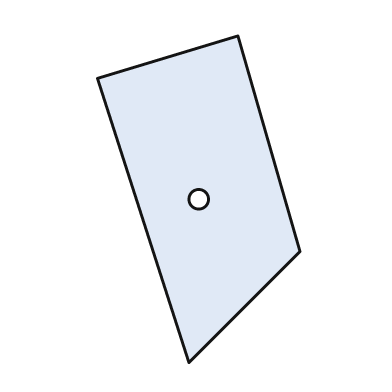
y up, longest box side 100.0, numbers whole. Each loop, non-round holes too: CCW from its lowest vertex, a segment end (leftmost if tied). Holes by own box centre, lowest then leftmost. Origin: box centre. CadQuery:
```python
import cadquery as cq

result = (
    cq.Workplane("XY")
    .moveTo(-3.0, -50.0)
    .lineTo(31.0, -16.0)
    .lineTo(12.0, 50.0)
    .lineTo(-31.0, 37.0)
    .close()
    .moveTo(0.0, 0.0)
    .circle(3.0)
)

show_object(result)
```